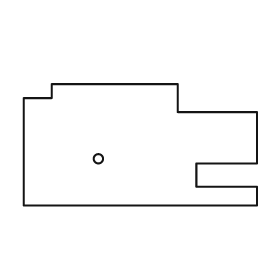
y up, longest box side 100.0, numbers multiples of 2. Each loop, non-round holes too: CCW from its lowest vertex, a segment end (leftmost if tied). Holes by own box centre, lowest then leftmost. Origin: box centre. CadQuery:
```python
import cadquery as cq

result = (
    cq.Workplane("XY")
    .moveTo(-50.0, -26.0)
    .lineTo(50.0, -26.0)
    .lineTo(50.0, -18.0)
    .lineTo(24.0, -18.0)
    .lineTo(24.0, -8.0)
    .lineTo(50.0, -8.0)
    .lineTo(50.0, 14.0)
    .lineTo(16.0, 14.0)
    .lineTo(16.0, 26.0)
    .lineTo(-38.0, 26.0)
    .lineTo(-38.0, 20.0)
    .lineTo(-50.0, 20.0)
    .close()
    .moveTo(-18.0, -6.0)
    .circle(2.0)
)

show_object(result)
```